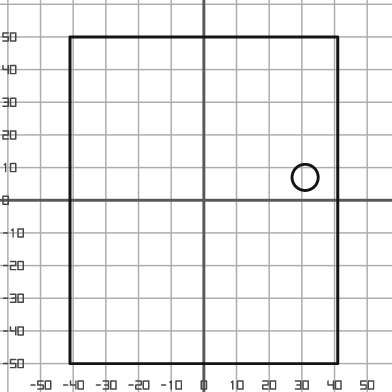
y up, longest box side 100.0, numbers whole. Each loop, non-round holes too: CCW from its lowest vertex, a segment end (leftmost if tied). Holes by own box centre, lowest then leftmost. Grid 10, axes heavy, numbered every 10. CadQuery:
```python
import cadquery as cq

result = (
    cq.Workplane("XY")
    .moveTo(-41.0, -50.0)
    .lineTo(41.0, -50.0)
    .lineTo(41.0, 50.0)
    .lineTo(-41.0, 50.0)
    .close()
    .moveTo(31.0, 7.0)
    .circle(4.0)
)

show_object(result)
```